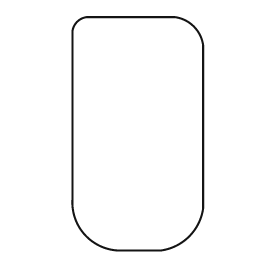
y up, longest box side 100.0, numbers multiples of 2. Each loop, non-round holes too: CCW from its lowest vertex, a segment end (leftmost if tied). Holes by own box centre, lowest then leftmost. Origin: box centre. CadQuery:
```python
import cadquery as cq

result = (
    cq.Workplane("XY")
    .moveTo(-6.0, -50.0)
    .lineTo(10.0, -50.0)
    .threePointArc((22.0, -44.0), (28.0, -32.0))
    .lineTo(28.0, 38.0)
    .threePointArc((24.0, 46.0), (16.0, 50.0))
    .lineTo(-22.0, 50.0)
    .threePointArc((-26.0, 48.0), (-28.0, 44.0))
    .lineTo(-28.0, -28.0)
    .threePointArc((-22.0, -44.0), (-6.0, -50.0))
    .close()
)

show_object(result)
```